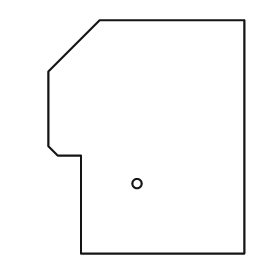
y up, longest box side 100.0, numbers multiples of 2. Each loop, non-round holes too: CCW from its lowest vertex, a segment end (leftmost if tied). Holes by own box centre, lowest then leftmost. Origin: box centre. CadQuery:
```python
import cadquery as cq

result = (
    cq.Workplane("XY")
    .moveTo(-28.0, -50.0)
    .lineTo(42.0, -50.0)
    .lineTo(42.0, 50.0)
    .lineTo(-20.0, 50.0)
    .lineTo(-42.0, 28.0)
    .lineTo(-42.0, -4.0)
    .lineTo(-38.0, -8.0)
    .lineTo(-28.0, -8.0)
    .close()
    .moveTo(-4.0, -20.0)
    .circle(2.0)
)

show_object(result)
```